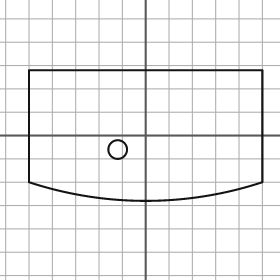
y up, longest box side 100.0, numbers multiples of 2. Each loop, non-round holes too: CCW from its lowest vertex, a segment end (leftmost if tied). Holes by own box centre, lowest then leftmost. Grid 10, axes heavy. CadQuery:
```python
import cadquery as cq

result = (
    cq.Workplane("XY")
    .moveTo(-50.0, -20.0)
    .threePointArc((0.0, -28.0), (50.0, -20.0))
    .lineTo(50.0, 28.0)
    .lineTo(-50.0, 28.0)
    .close()
    .moveTo(-12.0, -6.0)
    .circle(4.0)
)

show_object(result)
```